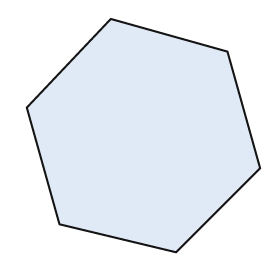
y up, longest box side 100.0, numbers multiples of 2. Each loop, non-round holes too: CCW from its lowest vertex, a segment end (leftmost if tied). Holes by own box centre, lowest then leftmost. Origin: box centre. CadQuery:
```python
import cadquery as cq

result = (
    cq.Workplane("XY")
    .moveTo(14.0, -50.0)
    .lineTo(50.0, -14.0)
    .lineTo(36.0, 36.0)
    .lineTo(-14.0, 50.0)
    .lineTo(-50.0, 12.0)
    .lineTo(-36.0, -38.0)
    .close()
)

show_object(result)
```